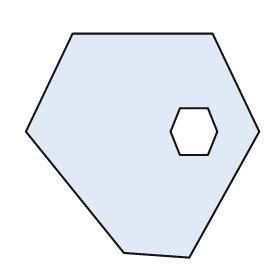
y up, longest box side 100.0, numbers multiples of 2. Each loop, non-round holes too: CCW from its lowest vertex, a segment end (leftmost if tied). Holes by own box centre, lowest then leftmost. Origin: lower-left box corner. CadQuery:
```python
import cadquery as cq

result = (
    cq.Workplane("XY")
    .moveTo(70.0, 0.0)
    .lineTo(100.0, 54.0)
    .lineTo(80.0, 96.0)
    .lineTo(20.0, 96.0)
    .lineTo(0.0, 54.0)
    .lineTo(42.0, 2.0)
    .close()
    .moveTo(66.0, 44.0)
    .lineTo(78.0, 44.0)
    .lineTo(82.0, 54.0)
    .lineTo(78.0, 64.0)
    .lineTo(66.0, 64.0)
    .lineTo(62.0, 54.0)
    .close()
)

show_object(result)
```